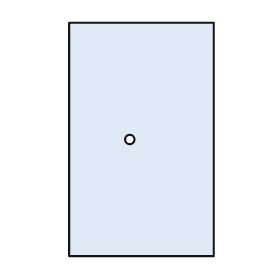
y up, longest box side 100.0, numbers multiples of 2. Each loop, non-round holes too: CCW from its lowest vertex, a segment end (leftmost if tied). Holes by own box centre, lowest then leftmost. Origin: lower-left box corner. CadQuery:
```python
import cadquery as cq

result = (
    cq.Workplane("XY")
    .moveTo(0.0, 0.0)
    .lineTo(62.0, 0.0)
    .lineTo(62.0, 100.0)
    .lineTo(0.0, 100.0)
    .close()
    .moveTo(26.0, 50.0)
    .circle(2.0)
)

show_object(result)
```